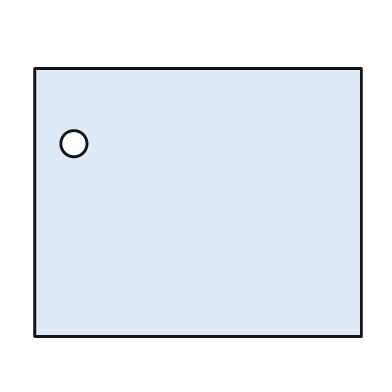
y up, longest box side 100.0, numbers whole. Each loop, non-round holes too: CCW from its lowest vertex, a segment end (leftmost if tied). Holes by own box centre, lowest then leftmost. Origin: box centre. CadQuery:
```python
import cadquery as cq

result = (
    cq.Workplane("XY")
    .moveTo(-50.0, -41.0)
    .lineTo(50.0, -41.0)
    .lineTo(50.0, 41.0)
    .lineTo(-50.0, 41.0)
    .close()
    .moveTo(-38.0, 18.0)
    .circle(4.0)
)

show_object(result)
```